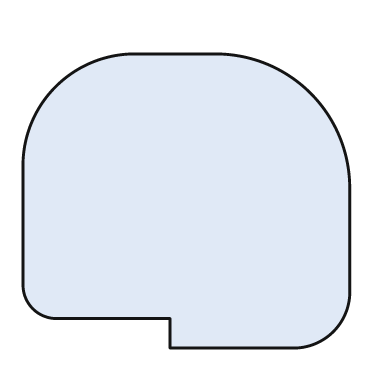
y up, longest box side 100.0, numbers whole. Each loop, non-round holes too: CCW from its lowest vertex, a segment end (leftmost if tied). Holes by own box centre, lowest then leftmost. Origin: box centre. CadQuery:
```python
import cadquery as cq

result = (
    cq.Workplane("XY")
    .moveTo(-5.0, -45.0)
    .lineTo(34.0, -45.0)
    .threePointArc((45.0, -40.0), (50.0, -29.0))
    .lineTo(50.0, 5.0)
    .threePointArc((38.0, 33.0), (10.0, 45.0))
    .lineTo(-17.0, 45.0)
    .threePointArc((-40.0, 35.0), (-50.0, 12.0))
    .lineTo(-50.0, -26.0)
    .threePointArc((-47.0, -33.0), (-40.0, -36.0))
    .lineTo(-5.0, -36.0)
    .close()
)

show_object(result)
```